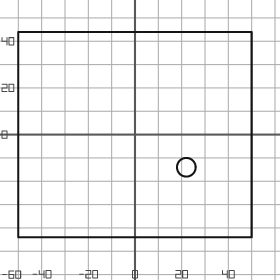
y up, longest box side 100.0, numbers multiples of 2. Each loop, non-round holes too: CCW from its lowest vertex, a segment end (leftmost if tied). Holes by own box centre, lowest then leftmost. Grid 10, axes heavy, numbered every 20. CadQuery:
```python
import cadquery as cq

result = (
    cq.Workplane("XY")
    .moveTo(-50.0, -44.0)
    .lineTo(50.0, -44.0)
    .lineTo(50.0, 44.0)
    .lineTo(-50.0, 44.0)
    .close()
    .moveTo(22.0, -14.0)
    .circle(4.0)
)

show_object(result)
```